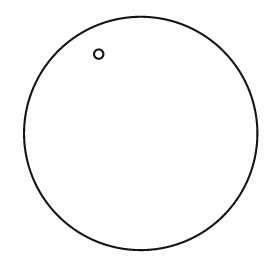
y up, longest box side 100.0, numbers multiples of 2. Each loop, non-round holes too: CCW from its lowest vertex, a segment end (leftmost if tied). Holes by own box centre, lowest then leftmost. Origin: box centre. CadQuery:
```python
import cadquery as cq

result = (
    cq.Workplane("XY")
    .moveTo(0.0, 0.0)
    .circle(50.0)
    .moveTo(-18.0, 34.0)
    .circle(2.0)
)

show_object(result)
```